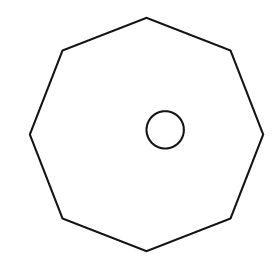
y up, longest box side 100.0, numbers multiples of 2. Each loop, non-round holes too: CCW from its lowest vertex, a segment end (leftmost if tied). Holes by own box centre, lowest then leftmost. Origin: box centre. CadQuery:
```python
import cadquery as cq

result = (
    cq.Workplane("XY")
    .moveTo(0.0, -50.0)
    .lineTo(36.0, -36.0)
    .lineTo(50.0, 0.0)
    .lineTo(36.0, 36.0)
    .lineTo(0.0, 50.0)
    .lineTo(-36.0, 36.0)
    .lineTo(-50.0, 0.0)
    .lineTo(-36.0, -36.0)
    .close()
    .moveTo(8.0, 2.0)
    .circle(8.0)
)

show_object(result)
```